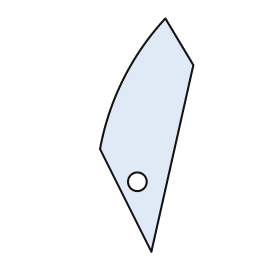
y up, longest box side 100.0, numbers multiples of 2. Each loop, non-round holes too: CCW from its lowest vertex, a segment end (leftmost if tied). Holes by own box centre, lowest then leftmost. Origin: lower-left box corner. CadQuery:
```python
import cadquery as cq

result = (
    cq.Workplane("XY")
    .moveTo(22.0, 0.0)
    .lineTo(40.0, 80.0)
    .lineTo(28.0, 100.0)
    .threePointArc((10.0, 74.0), (0.0, 44.0))
    .close()
    .moveTo(16.0, 30.0)
    .circle(4.0)
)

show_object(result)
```